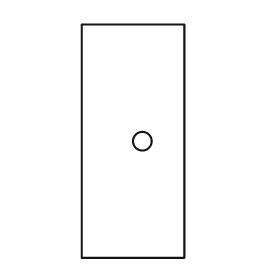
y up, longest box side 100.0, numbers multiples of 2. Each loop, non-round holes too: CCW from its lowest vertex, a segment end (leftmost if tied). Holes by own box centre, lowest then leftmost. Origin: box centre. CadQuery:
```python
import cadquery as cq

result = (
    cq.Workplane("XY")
    .moveTo(-22.0, -50.0)
    .lineTo(22.0, -50.0)
    .lineTo(22.0, 50.0)
    .lineTo(-22.0, 50.0)
    .close()
    .moveTo(4.0, 0.0)
    .circle(4.0)
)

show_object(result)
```